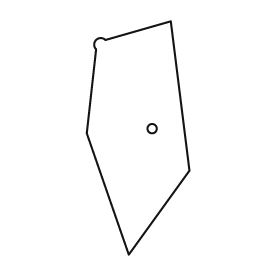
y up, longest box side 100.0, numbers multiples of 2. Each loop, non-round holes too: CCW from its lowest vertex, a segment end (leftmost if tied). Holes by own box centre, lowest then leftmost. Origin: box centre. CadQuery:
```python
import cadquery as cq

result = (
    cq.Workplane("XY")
    .moveTo(-4.0, -50.0)
    .lineTo(22.0, -14.0)
    .lineTo(14.0, 50.0)
    .lineTo(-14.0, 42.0)
    .threePointArc((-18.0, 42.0), (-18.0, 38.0))
    .lineTo(-22.0, 2.0)
    .close()
    .moveTo(6.0, 4.0)
    .circle(2.0)
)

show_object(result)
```